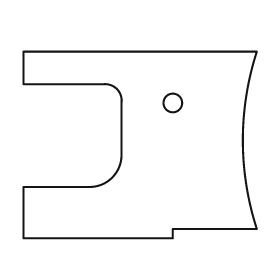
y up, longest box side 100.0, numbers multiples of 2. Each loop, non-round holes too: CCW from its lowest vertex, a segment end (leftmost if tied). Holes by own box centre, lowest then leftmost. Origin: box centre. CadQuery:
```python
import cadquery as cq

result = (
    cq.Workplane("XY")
    .moveTo(-50.0, -40.0)
    .lineTo(14.0, -40.0)
    .lineTo(14.0, -36.0)
    .lineTo(50.0, -36.0)
    .threePointArc((44.0, 2.0), (50.0, 40.0))
    .lineTo(-50.0, 40.0)
    .lineTo(-50.0, 26.0)
    .lineTo(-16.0, 26.0)
    .threePointArc((-10.0, 24.0), (-8.0, 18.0))
    .lineTo(-8.0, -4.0)
    .threePointArc((-12.0, -14.0), (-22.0, -18.0))
    .lineTo(-50.0, -18.0)
    .close()
    .moveTo(14.0, 18.0)
    .circle(4.0)
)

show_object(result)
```